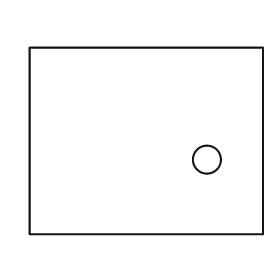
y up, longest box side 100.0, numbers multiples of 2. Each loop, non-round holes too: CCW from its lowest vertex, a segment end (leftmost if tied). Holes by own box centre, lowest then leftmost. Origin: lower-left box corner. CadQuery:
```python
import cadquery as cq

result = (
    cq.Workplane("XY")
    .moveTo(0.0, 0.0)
    .lineTo(100.0, 0.0)
    .lineTo(100.0, 80.0)
    .lineTo(0.0, 80.0)
    .close()
    .moveTo(76.0, 32.0)
    .circle(6.0)
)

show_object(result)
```